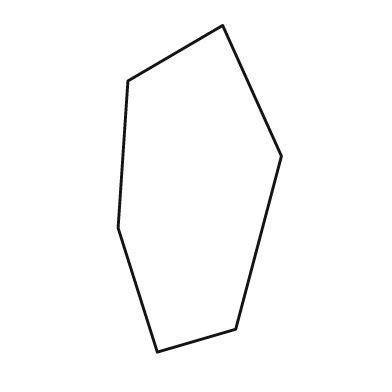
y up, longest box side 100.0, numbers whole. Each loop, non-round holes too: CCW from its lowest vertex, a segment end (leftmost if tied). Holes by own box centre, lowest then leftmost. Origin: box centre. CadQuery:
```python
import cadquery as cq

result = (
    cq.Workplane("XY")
    .moveTo(-13.0, -50.0)
    .lineTo(11.0, -43.0)
    .lineTo(25.0, 10.0)
    .lineTo(7.0, 50.0)
    .lineTo(-22.0, 33.0)
    .lineTo(-25.0, -12.0)
    .close()
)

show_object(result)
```